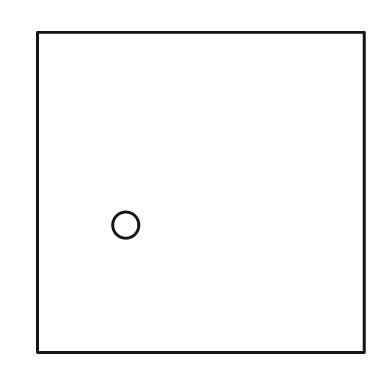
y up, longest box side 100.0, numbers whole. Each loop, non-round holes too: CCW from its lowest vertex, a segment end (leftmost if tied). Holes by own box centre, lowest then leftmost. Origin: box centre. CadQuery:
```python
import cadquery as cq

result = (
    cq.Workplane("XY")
    .moveTo(-50.0, -49.0)
    .lineTo(50.0, -49.0)
    .lineTo(50.0, 49.0)
    .lineTo(-50.0, 49.0)
    .close()
    .moveTo(-23.0, -10.0)
    .circle(4.0)
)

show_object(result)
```